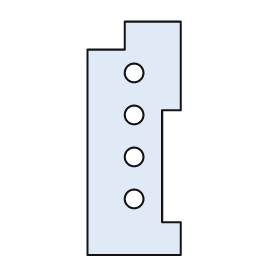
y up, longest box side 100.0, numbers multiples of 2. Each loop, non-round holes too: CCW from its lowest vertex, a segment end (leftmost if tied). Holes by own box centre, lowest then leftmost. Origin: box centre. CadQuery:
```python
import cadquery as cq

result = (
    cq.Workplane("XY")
    .moveTo(-20.0, -50.0)
    .lineTo(20.0, -50.0)
    .lineTo(20.0, -36.0)
    .lineTo(12.0, -36.0)
    .lineTo(12.0, 12.0)
    .lineTo(20.0, 12.0)
    .lineTo(20.0, 50.0)
    .lineTo(-4.0, 50.0)
    .lineTo(-4.0, 38.0)
    .lineTo(-20.0, 38.0)
    .close()
    .moveTo(0.0, -26.0)
    .circle(4.0)
    .moveTo(0.0, -8.0)
    .circle(4.0)
    .moveTo(0.0, 10.0)
    .circle(4.0)
    .moveTo(0.0, 28.0)
    .circle(4.0)
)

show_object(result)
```